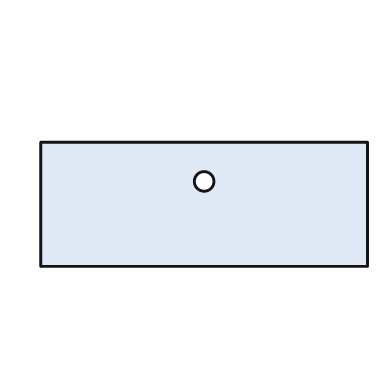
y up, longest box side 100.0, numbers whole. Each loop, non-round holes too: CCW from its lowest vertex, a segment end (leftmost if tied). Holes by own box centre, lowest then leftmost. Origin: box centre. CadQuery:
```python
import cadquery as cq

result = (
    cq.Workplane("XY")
    .moveTo(-50.0, -19.0)
    .lineTo(50.0, -19.0)
    .lineTo(50.0, 19.0)
    .lineTo(-50.0, 19.0)
    .close()
    .moveTo(0.0, 7.0)
    .circle(3.0)
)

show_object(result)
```